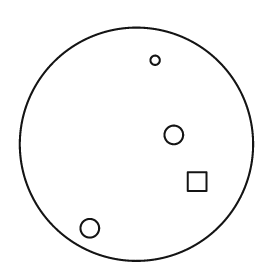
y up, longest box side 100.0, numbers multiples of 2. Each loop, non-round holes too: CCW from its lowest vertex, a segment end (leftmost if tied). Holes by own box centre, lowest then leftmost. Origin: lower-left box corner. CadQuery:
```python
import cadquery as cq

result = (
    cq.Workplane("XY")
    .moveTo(50.0, 50.0)
    .circle(50.0)
    .moveTo(30.0, 14.0)
    .circle(4.0)
    .moveTo(72.0, 30.0)
    .lineTo(80.0, 30.0)
    .lineTo(80.0, 38.0)
    .lineTo(72.0, 38.0)
    .close()
    .moveTo(66.0, 54.0)
    .circle(4.0)
    .moveTo(58.0, 86.0)
    .circle(2.0)
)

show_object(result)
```